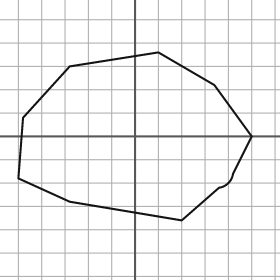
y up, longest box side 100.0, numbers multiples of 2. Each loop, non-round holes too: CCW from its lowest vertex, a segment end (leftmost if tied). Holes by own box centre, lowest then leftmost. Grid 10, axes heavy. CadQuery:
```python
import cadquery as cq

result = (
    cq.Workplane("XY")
    .moveTo(20.0, -36.0)
    .lineTo(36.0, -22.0)
    .threePointArc((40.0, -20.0), (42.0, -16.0))
    .lineTo(50.0, 0.0)
    .lineTo(34.0, 22.0)
    .lineTo(10.0, 36.0)
    .lineTo(-28.0, 30.0)
    .lineTo(-48.0, 8.0)
    .lineTo(-50.0, -18.0)
    .lineTo(-28.0, -28.0)
    .close()
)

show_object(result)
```